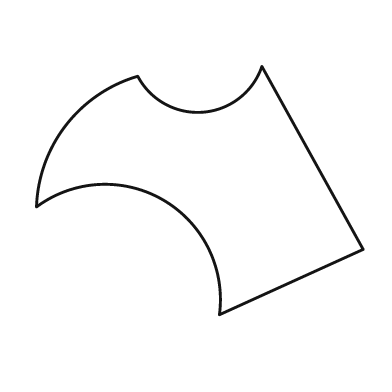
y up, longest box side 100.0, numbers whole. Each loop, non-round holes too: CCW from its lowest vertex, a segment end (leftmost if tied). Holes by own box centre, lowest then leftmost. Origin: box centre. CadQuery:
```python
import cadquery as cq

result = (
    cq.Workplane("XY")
    .moveTo(6.0, -38.0)
    .lineTo(50.0, -18.0)
    .lineTo(19.0, 38.0)
    .threePointArc((1.0, 24.0), (-19.0, 35.0))
    .threePointArc((-41.0, 20.0), (-50.0, -5.0))
    .threePointArc((-11.0, -3.0), (6.0, -38.0))
    .close()
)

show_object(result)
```